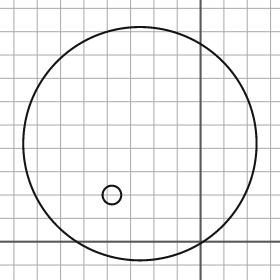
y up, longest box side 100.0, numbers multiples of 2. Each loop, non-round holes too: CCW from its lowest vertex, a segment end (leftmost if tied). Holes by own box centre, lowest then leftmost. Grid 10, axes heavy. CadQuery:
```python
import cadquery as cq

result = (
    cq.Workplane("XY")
    .moveTo(-26.0, 42.0)
    .circle(50.0)
    .moveTo(-38.0, 20.0)
    .circle(4.0)
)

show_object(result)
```